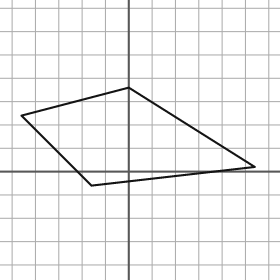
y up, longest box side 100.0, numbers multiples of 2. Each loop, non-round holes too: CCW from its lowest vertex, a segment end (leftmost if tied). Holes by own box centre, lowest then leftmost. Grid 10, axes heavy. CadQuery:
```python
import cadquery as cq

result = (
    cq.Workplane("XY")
    .moveTo(-16.0, -6.0)
    .lineTo(54.0, 2.0)
    .lineTo(0.0, 36.0)
    .lineTo(-46.0, 24.0)
    .close()
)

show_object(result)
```